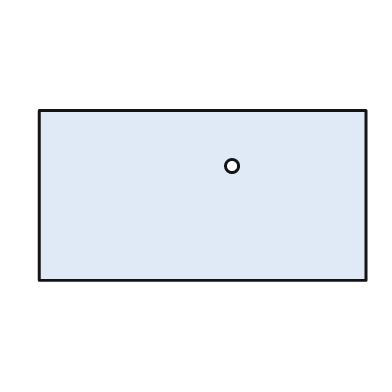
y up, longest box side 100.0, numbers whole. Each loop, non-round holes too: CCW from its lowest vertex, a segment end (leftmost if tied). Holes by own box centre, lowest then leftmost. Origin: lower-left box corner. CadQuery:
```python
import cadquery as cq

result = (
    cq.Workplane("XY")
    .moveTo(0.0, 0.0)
    .lineTo(100.0, 0.0)
    .lineTo(100.0, 52.0)
    .lineTo(0.0, 52.0)
    .close()
    .moveTo(59.0, 35.0)
    .circle(2.0)
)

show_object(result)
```